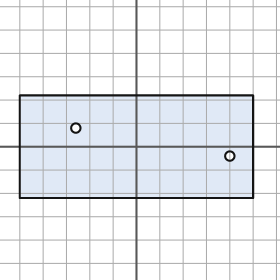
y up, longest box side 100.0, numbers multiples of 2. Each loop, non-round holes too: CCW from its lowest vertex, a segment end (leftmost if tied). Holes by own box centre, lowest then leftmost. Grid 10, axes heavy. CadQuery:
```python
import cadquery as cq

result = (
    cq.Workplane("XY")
    .moveTo(-50.0, -22.0)
    .lineTo(50.0, -22.0)
    .lineTo(50.0, 22.0)
    .lineTo(-50.0, 22.0)
    .close()
    .moveTo(40.0, -4.0)
    .circle(2.0)
    .moveTo(-26.0, 8.0)
    .circle(2.0)
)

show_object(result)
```